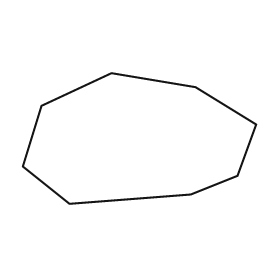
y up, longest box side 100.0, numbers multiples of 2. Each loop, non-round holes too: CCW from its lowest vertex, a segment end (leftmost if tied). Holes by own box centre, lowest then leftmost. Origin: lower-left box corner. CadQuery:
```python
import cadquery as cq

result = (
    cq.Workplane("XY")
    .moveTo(20.0, 0.0)
    .lineTo(72.0, 4.0)
    .lineTo(92.0, 12.0)
    .lineTo(100.0, 34.0)
    .lineTo(74.0, 50.0)
    .lineTo(38.0, 56.0)
    .lineTo(8.0, 42.0)
    .lineTo(0.0, 16.0)
    .close()
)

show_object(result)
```